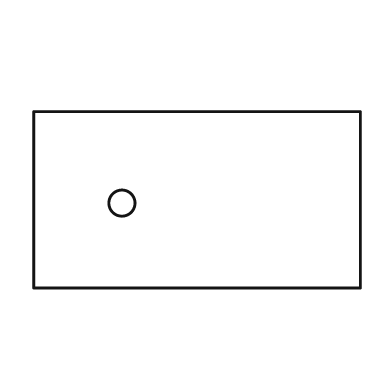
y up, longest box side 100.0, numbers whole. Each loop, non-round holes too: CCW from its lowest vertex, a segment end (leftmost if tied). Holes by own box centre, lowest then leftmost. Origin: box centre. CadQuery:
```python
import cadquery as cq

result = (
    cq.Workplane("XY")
    .moveTo(-50.0, -27.0)
    .lineTo(50.0, -27.0)
    .lineTo(50.0, 27.0)
    .lineTo(-50.0, 27.0)
    .close()
    .moveTo(-23.0, -1.0)
    .circle(4.0)
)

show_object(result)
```